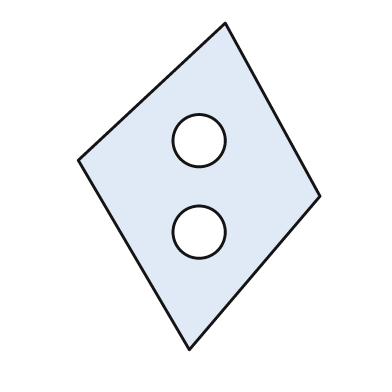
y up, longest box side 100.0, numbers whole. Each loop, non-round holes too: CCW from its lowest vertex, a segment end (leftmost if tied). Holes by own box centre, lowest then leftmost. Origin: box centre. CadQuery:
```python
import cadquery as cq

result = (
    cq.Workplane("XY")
    .moveTo(-3.0, -50.0)
    .lineTo(37.0, -3.0)
    .lineTo(8.0, 50.0)
    .lineTo(-37.0, 8.0)
    .close()
    .moveTo(0.0, -14.0)
    .circle(8.0)
    .moveTo(0.0, 14.0)
    .circle(8.0)
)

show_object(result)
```